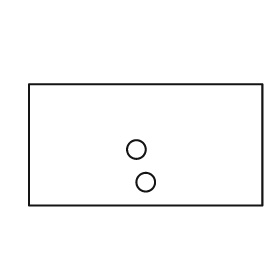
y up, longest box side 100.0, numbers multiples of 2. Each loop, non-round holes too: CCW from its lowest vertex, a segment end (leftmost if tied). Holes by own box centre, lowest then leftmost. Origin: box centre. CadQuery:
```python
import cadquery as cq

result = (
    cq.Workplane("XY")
    .moveTo(-50.0, -26.0)
    .lineTo(50.0, -26.0)
    .lineTo(50.0, 26.0)
    .lineTo(-50.0, 26.0)
    .close()
    .moveTo(0.0, -16.0)
    .circle(4.0)
    .moveTo(-4.0, -2.0)
    .circle(4.0)
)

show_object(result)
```